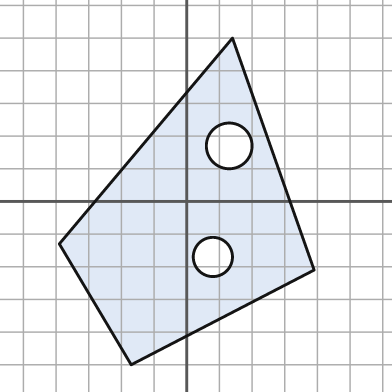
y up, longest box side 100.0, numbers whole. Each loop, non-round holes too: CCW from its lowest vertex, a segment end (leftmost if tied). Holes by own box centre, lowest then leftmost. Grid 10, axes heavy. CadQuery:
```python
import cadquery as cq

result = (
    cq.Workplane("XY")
    .moveTo(-17.0, -50.0)
    .lineTo(39.0, -21.0)
    .lineTo(14.0, 50.0)
    .lineTo(-39.0, -13.0)
    .close()
    .moveTo(8.0, -17.0)
    .circle(6.0)
    .moveTo(13.0, 17.0)
    .circle(7.0)
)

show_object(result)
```